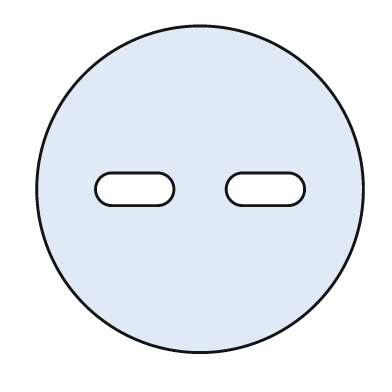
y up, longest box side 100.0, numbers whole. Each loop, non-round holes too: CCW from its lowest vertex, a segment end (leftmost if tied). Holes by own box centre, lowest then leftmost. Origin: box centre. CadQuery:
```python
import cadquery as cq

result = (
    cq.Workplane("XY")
    .moveTo(0.0, 0.0)
    .circle(50.0)
    .moveTo(-27.0, -5.0)
    .lineTo(-13.0, -5.0)
    .threePointArc((-8.0, 0.0), (-13.0, 5.0))
    .lineTo(-27.0, 5.0)
    .threePointArc((-32.0, 0.0), (-27.0, -5.0))
    .close()
    .moveTo(13.0, -5.0)
    .lineTo(27.0, -5.0)
    .threePointArc((32.0, 0.0), (27.0, 5.0))
    .lineTo(13.0, 5.0)
    .threePointArc((8.0, 0.0), (13.0, -5.0))
    .close()
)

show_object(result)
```